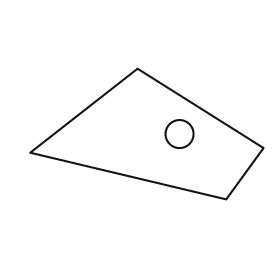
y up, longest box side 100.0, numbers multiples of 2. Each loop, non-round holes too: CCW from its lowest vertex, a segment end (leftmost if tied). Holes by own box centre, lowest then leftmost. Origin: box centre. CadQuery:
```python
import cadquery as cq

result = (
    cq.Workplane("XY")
    .moveTo(34.0, -28.0)
    .lineTo(50.0, -6.0)
    .lineTo(-4.0, 28.0)
    .lineTo(-50.0, -8.0)
    .close()
    .moveTo(14.0, 0.0)
    .circle(6.0)
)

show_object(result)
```